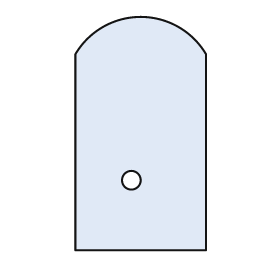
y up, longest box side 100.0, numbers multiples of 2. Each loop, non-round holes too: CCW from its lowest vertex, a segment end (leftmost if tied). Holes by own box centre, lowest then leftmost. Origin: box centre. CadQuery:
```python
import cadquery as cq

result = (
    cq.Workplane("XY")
    .moveTo(-28.0, -50.0)
    .lineTo(28.0, -50.0)
    .lineTo(28.0, 34.0)
    .threePointArc((0.0, 50.0), (-28.0, 34.0))
    .close()
    .moveTo(-4.0, -20.0)
    .circle(4.0)
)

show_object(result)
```